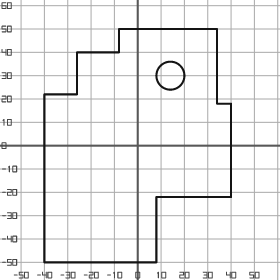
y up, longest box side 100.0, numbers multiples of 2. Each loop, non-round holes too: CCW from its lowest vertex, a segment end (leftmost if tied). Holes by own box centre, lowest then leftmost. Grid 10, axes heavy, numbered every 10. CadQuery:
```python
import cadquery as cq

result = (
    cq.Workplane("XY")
    .moveTo(-40.0, -50.0)
    .lineTo(8.0, -50.0)
    .lineTo(8.0, -22.0)
    .lineTo(40.0, -22.0)
    .lineTo(40.0, 18.0)
    .lineTo(34.0, 18.0)
    .lineTo(34.0, 50.0)
    .lineTo(-8.0, 50.0)
    .lineTo(-8.0, 40.0)
    .lineTo(-26.0, 40.0)
    .lineTo(-26.0, 22.0)
    .lineTo(-40.0, 22.0)
    .close()
    .moveTo(14.0, 30.0)
    .circle(6.0)
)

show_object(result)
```